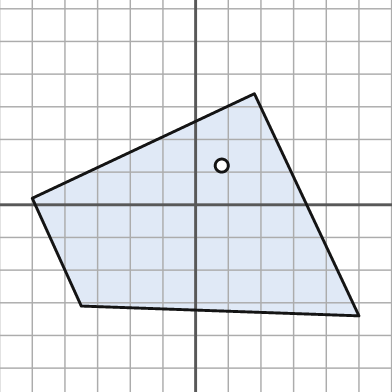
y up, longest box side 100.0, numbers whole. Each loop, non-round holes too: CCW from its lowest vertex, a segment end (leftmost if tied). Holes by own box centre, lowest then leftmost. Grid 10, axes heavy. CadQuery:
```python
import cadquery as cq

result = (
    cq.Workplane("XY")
    .moveTo(50.0, -34.0)
    .lineTo(18.0, 34.0)
    .lineTo(-50.0, 2.0)
    .lineTo(-35.0, -31.0)
    .close()
    .moveTo(8.0, 12.0)
    .circle(2.0)
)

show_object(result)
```